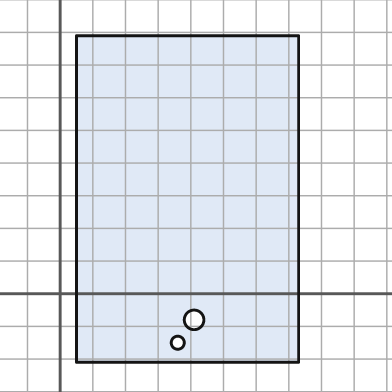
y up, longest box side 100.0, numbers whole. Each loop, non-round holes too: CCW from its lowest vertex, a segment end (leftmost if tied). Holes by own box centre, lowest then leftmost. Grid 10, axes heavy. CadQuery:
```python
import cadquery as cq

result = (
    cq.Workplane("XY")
    .moveTo(5.0, -21.0)
    .lineTo(73.0, -21.0)
    .lineTo(73.0, 79.0)
    .lineTo(5.0, 79.0)
    .close()
    .moveTo(36.0, -15.0)
    .circle(2.0)
    .moveTo(41.0, -8.0)
    .circle(3.0)
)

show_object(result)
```